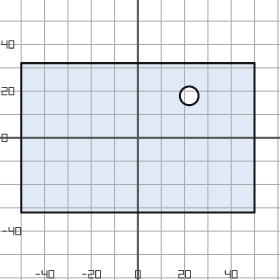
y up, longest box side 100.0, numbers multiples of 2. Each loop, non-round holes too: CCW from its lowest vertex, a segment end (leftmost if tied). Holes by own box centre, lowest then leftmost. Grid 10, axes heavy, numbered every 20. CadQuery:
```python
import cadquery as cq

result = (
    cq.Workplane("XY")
    .moveTo(-50.0, -32.0)
    .lineTo(50.0, -32.0)
    .lineTo(50.0, 32.0)
    .lineTo(-50.0, 32.0)
    .close()
    .moveTo(22.0, 18.0)
    .circle(4.0)
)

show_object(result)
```